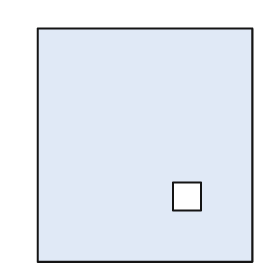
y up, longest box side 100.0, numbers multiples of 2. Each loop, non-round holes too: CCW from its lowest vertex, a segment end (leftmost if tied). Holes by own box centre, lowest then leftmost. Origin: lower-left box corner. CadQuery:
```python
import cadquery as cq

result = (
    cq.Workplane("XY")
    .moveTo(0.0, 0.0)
    .lineTo(92.0, 0.0)
    .lineTo(92.0, 100.0)
    .lineTo(0.0, 100.0)
    .close()
    .moveTo(58.0, 22.0)
    .lineTo(70.0, 22.0)
    .lineTo(70.0, 34.0)
    .lineTo(58.0, 34.0)
    .close()
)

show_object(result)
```